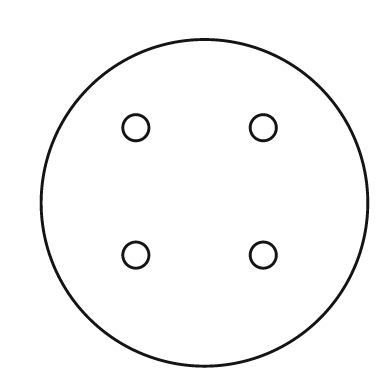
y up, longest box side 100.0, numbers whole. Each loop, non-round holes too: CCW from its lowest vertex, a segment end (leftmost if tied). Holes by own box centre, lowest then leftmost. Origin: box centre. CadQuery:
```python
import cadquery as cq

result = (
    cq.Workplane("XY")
    .moveTo(0.0, 0.0)
    .circle(50.0)
    .moveTo(-21.0, -16.0)
    .circle(4.0)
    .moveTo(18.0, -16.0)
    .circle(4.0)
    .moveTo(-21.0, 23.0)
    .circle(4.0)
    .moveTo(18.0, 23.0)
    .circle(4.0)
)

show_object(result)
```